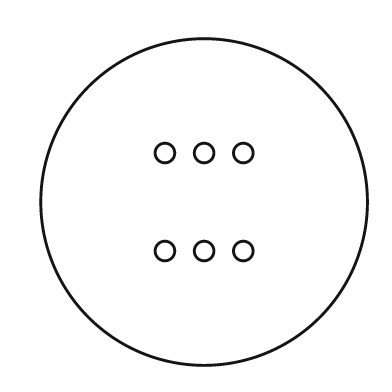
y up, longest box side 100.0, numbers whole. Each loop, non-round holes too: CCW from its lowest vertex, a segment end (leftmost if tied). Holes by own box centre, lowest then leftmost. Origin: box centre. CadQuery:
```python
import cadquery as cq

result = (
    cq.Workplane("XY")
    .moveTo(0.0, 0.0)
    .circle(50.0)
    .moveTo(-12.0, -15.0)
    .circle(3.0)
    .moveTo(0.0, -15.0)
    .circle(3.0)
    .moveTo(12.0, -15.0)
    .circle(3.0)
    .moveTo(-12.0, 15.0)
    .circle(3.0)
    .moveTo(0.0, 15.0)
    .circle(3.0)
    .moveTo(12.0, 15.0)
    .circle(3.0)
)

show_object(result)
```